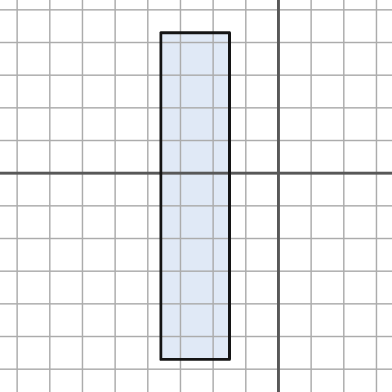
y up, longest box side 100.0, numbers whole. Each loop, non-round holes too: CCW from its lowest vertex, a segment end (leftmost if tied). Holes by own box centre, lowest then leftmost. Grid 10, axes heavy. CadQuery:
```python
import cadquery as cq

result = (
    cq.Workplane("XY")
    .moveTo(-36.0, -57.0)
    .lineTo(-15.0, -57.0)
    .lineTo(-15.0, 43.0)
    .lineTo(-36.0, 43.0)
    .close()
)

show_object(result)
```